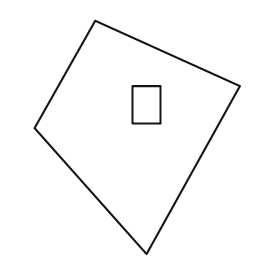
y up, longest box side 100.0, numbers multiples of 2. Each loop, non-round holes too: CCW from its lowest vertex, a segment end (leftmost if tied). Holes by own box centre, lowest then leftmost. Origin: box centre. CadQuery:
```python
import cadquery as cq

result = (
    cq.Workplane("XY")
    .moveTo(4.0, -50.0)
    .lineTo(44.0, 22.0)
    .lineTo(-18.0, 50.0)
    .lineTo(-44.0, 4.0)
    .close()
    .moveTo(-2.0, 6.0)
    .lineTo(10.0, 6.0)
    .lineTo(10.0, 22.0)
    .lineTo(-2.0, 22.0)
    .close()
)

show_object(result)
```